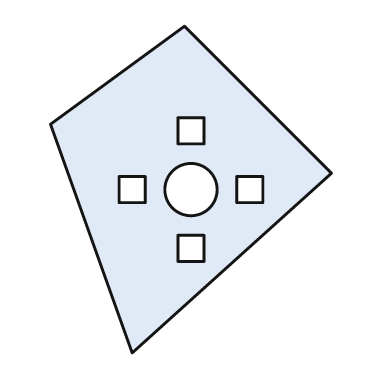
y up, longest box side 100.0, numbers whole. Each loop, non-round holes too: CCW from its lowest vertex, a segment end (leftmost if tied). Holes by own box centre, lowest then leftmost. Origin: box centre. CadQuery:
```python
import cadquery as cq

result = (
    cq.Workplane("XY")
    .moveTo(-18.0, -50.0)
    .lineTo(43.0, 5.0)
    .lineTo(-2.0, 50.0)
    .lineTo(-43.0, 20.0)
    .close()
    .moveTo(-4.0, -22.0)
    .lineTo(4.0, -22.0)
    .lineTo(4.0, -14.0)
    .lineTo(-4.0, -14.0)
    .close()
    .moveTo(-22.0, -4.0)
    .lineTo(-14.0, -4.0)
    .lineTo(-14.0, 4.0)
    .lineTo(-22.0, 4.0)
    .close()
    .moveTo(0.0, 0.0)
    .circle(8.0)
    .moveTo(14.0, -4.0)
    .lineTo(22.0, -4.0)
    .lineTo(22.0, 4.0)
    .lineTo(14.0, 4.0)
    .close()
    .moveTo(-4.0, 14.0)
    .lineTo(4.0, 14.0)
    .lineTo(4.0, 22.0)
    .lineTo(-4.0, 22.0)
    .close()
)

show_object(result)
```